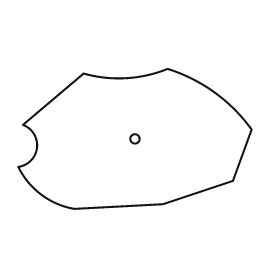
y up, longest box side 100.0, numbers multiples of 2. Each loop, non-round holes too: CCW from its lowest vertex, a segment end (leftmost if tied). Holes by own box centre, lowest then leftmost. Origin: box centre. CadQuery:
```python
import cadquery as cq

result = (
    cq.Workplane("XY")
    .moveTo(-26.0, -30.0)
    .lineTo(12.0, -28.0)
    .lineTo(42.0, -18.0)
    .lineTo(50.0, 4.0)
    .threePointArc((34.0, 20.0), (14.0, 30.0))
    .threePointArc((-4.0, 26.0), (-22.0, 28.0))
    .lineTo(-48.0, 6.0)
    .threePointArc((-42.0, -4.0), (-50.0, -12.0))
    .threePointArc((-40.0, -24.0), (-26.0, -30.0))
    .close()
    .moveTo(0.0, 0.0)
    .circle(2.0)
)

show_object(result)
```